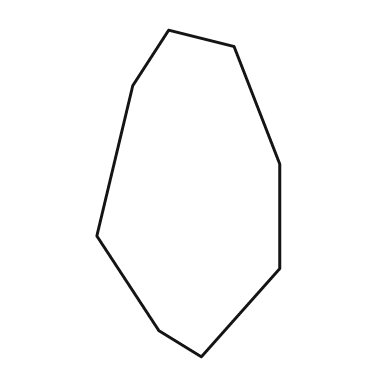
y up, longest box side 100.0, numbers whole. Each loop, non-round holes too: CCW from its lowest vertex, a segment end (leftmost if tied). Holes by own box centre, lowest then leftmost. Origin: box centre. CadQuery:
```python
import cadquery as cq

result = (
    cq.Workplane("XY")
    .moveTo(4.0, -50.0)
    .lineTo(28.0, -23.0)
    .lineTo(28.0, 9.0)
    .lineTo(14.0, 45.0)
    .lineTo(-6.0, 50.0)
    .lineTo(-17.0, 33.0)
    .lineTo(-28.0, -13.0)
    .lineTo(-9.0, -42.0)
    .close()
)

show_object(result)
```